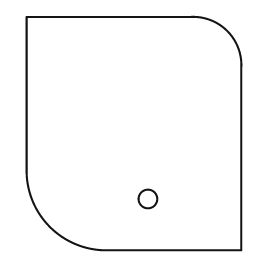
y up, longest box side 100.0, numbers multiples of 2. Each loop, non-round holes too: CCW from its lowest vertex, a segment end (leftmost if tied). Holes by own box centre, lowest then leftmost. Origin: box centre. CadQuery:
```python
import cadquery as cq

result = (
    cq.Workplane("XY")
    .moveTo(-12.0, -50.0)
    .lineTo(46.0, -50.0)
    .lineTo(46.0, 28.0)
    .threePointArc((40.0, 44.0), (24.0, 50.0))
    .lineTo(-46.0, 50.0)
    .lineTo(-46.0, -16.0)
    .threePointArc((-36.0, -40.0), (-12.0, -50.0))
    .close()
    .moveTo(6.0, -28.0)
    .circle(4.0)
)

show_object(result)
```